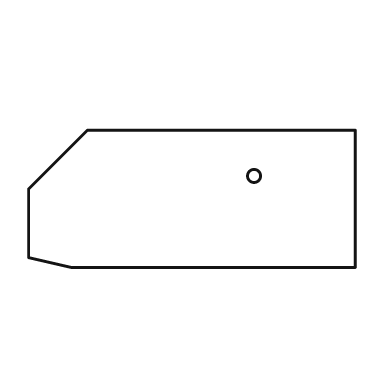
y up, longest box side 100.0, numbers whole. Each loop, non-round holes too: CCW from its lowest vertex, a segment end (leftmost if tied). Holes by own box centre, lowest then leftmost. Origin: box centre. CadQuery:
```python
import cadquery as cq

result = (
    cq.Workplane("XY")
    .moveTo(-37.0, -21.0)
    .lineTo(50.0, -21.0)
    .lineTo(50.0, 21.0)
    .lineTo(-32.0, 21.0)
    .lineTo(-50.0, 3.0)
    .lineTo(-50.0, -18.0)
    .close()
    .moveTo(19.0, 7.0)
    .circle(2.0)
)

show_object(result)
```